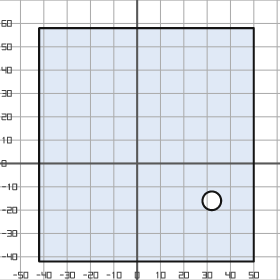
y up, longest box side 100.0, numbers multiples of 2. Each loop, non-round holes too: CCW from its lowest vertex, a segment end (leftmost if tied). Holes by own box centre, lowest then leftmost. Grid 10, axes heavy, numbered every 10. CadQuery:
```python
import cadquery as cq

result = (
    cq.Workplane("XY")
    .moveTo(-42.0, -42.0)
    .lineTo(50.0, -42.0)
    .lineTo(50.0, 58.0)
    .lineTo(-42.0, 58.0)
    .close()
    .moveTo(32.0, -16.0)
    .circle(4.0)
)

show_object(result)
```